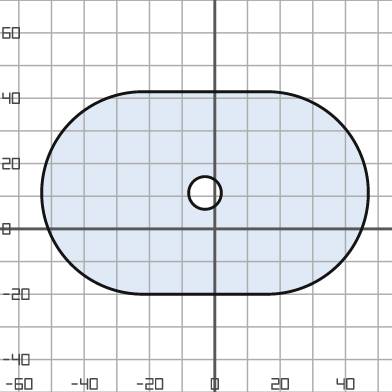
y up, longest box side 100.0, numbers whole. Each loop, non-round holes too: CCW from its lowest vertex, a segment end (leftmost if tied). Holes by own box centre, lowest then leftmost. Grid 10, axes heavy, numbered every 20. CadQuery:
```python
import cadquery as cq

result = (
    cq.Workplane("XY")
    .moveTo(-22.0, -20.0)
    .lineTo(16.0, -20.0)
    .threePointArc((47.0, 11.0), (16.0, 42.0))
    .lineTo(-22.0, 42.0)
    .threePointArc((-53.0, 11.0), (-22.0, -20.0))
    .close()
    .moveTo(-3.0, 11.0)
    .circle(5.0)
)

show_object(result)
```